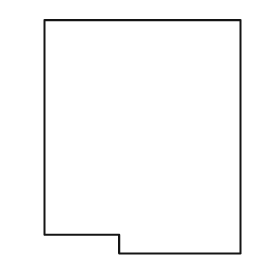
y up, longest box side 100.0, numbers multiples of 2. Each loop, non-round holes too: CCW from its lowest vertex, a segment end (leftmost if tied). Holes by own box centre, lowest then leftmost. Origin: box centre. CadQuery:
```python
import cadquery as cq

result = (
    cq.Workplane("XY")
    .moveTo(-10.0, -50.0)
    .lineTo(42.0, -50.0)
    .lineTo(42.0, 50.0)
    .lineTo(-42.0, 50.0)
    .lineTo(-42.0, -42.0)
    .lineTo(-10.0, -42.0)
    .close()
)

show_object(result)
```